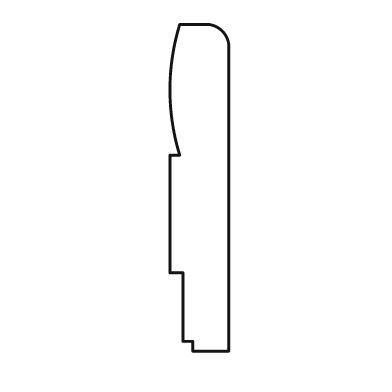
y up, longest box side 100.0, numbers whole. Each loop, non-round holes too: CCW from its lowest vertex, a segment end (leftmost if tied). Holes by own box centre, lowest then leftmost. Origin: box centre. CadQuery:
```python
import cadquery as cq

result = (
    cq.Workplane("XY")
    .moveTo(-2.0, -50.0)
    .lineTo(9.0, -50.0)
    .lineTo(9.0, 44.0)
    .threePointArc((7.0, 48.0), (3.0, 50.0))
    .lineTo(-6.0, 50.0)
    .threePointArc((-9.0, 30.0), (-6.0, 10.0))
    .lineTo(-9.0, 10.0)
    .lineTo(-9.0, -26.0)
    .lineTo(-5.0, -26.0)
    .lineTo(-5.0, -47.0)
    .lineTo(-2.0, -47.0)
    .close()
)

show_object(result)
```